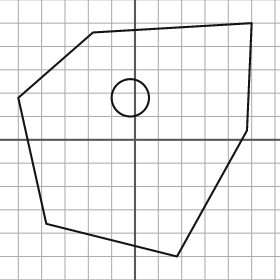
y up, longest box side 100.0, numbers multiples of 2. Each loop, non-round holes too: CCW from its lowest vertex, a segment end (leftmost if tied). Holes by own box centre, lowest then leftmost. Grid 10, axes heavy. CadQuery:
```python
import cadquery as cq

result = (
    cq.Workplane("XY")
    .moveTo(18.0, -50.0)
    .lineTo(48.0, 4.0)
    .lineTo(50.0, 50.0)
    .lineTo(-18.0, 46.0)
    .lineTo(-50.0, 18.0)
    .lineTo(-38.0, -36.0)
    .close()
    .moveTo(-2.0, 18.0)
    .circle(8.0)
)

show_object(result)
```